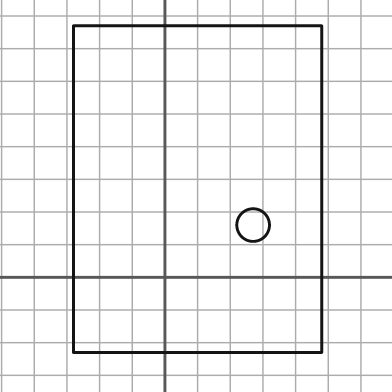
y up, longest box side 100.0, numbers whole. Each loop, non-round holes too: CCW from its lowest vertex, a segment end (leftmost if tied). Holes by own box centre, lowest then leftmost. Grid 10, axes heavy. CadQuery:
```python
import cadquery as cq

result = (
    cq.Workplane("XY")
    .moveTo(-28.0, -23.0)
    .lineTo(48.0, -23.0)
    .lineTo(48.0, 77.0)
    .lineTo(-28.0, 77.0)
    .close()
    .moveTo(27.0, 16.0)
    .circle(5.0)
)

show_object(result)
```